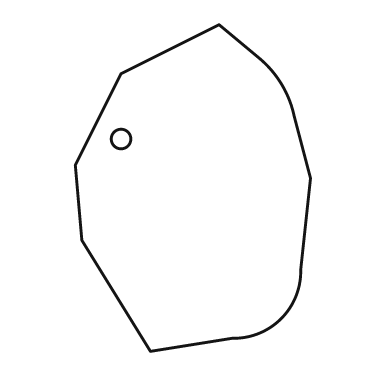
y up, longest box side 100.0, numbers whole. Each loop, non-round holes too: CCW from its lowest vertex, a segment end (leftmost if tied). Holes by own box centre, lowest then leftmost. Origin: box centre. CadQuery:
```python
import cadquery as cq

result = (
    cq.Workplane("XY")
    .moveTo(-13.0, -50.0)
    .lineTo(12.0, -46.0)
    .threePointArc((27.0, -40.0), (33.0, -25.0))
    .lineTo(36.0, 3.0)
    .lineTo(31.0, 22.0)
    .threePointArc((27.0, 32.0), (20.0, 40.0))
    .lineTo(8.0, 50.0)
    .lineTo(-22.0, 35.0)
    .lineTo(-36.0, 7.0)
    .lineTo(-34.0, -16.0)
    .close()
    .moveTo(-22.0, 15.0)
    .circle(3.0)
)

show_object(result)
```